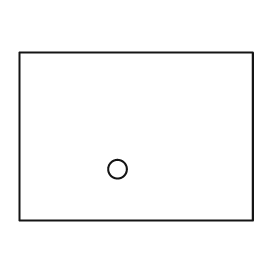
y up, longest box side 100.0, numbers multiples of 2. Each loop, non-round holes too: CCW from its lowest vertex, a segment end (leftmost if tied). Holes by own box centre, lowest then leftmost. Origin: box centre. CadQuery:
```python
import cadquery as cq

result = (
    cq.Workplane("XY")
    .moveTo(-50.0, -36.0)
    .lineTo(50.0, -36.0)
    .lineTo(50.0, 36.0)
    .lineTo(-50.0, 36.0)
    .close()
    .moveTo(-8.0, -14.0)
    .circle(4.0)
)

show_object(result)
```